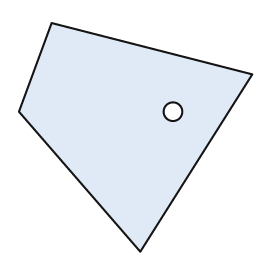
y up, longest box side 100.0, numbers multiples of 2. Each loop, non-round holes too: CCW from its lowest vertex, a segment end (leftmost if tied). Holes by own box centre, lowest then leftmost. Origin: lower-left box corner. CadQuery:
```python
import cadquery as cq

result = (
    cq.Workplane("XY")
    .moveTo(52.0, 0.0)
    .lineTo(100.0, 76.0)
    .lineTo(14.0, 98.0)
    .lineTo(0.0, 60.0)
    .close()
    .moveTo(66.0, 60.0)
    .circle(4.0)
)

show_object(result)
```